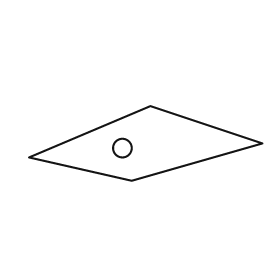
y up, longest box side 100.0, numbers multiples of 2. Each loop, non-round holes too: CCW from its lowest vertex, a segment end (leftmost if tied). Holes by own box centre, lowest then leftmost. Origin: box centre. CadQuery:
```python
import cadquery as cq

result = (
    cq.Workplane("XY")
    .moveTo(-6.0, -16.0)
    .lineTo(50.0, 0.0)
    .lineTo(2.0, 16.0)
    .lineTo(-50.0, -6.0)
    .close()
    .moveTo(-10.0, -2.0)
    .circle(4.0)
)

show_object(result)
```